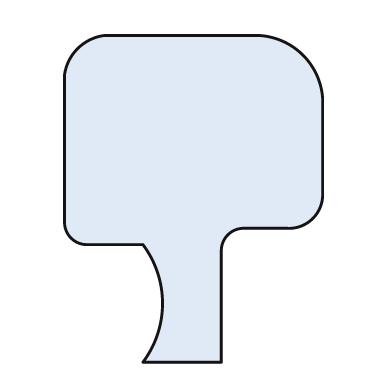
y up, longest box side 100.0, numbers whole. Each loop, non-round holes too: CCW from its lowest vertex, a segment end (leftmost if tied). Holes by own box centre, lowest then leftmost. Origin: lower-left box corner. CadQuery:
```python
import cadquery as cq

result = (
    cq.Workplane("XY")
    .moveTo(24.0, 0.0)
    .lineTo(48.0, 0.0)
    .lineTo(48.0, 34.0)
    .threePointArc((50.0, 39.0), (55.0, 41.0))
    .lineTo(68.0, 41.0)
    .threePointArc((76.0, 44.0), (79.0, 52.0))
    .lineTo(79.0, 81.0)
    .threePointArc((73.0, 94.0), (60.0, 100.0))
    .lineTo(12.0, 100.0)
    .threePointArc((4.0, 96.0), (0.0, 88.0))
    .lineTo(0.0, 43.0)
    .threePointArc((2.0, 38.0), (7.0, 36.0))
    .lineTo(24.0, 36.0)
    .threePointArc((30.0, 18.0), (24.0, 0.0))
    .close()
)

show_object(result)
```